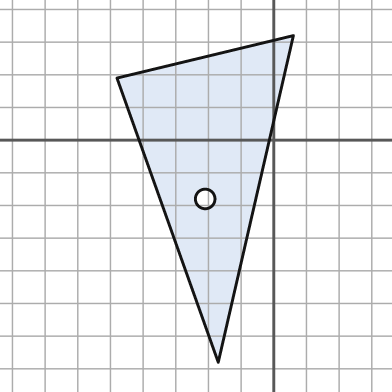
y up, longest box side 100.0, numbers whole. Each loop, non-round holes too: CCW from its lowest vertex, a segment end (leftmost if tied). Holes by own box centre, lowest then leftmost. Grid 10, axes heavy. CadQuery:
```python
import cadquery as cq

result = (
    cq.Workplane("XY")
    .moveTo(-17.0, -68.0)
    .lineTo(6.0, 32.0)
    .lineTo(-48.0, 19.0)
    .close()
    .moveTo(-21.0, -18.0)
    .circle(3.0)
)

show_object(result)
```